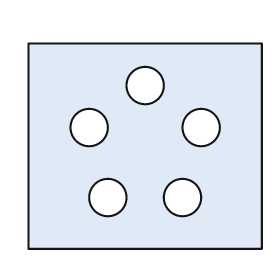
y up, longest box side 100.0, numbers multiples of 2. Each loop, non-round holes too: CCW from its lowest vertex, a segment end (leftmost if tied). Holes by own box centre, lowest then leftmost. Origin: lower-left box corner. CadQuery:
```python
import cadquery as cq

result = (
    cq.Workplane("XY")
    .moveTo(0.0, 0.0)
    .lineTo(100.0, 0.0)
    .lineTo(100.0, 88.0)
    .lineTo(0.0, 88.0)
    .close()
    .moveTo(34.0, 22.0)
    .circle(8.0)
    .moveTo(66.0, 22.0)
    .circle(8.0)
    .moveTo(26.0, 52.0)
    .circle(8.0)
    .moveTo(74.0, 52.0)
    .circle(8.0)
    .moveTo(50.0, 70.0)
    .circle(8.0)
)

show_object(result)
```